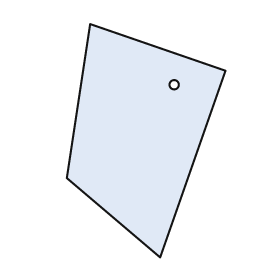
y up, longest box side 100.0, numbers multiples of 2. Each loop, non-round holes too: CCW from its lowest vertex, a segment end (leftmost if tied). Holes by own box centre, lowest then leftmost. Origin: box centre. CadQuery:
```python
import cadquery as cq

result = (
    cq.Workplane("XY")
    .moveTo(6.0, -50.0)
    .lineTo(34.0, 30.0)
    .lineTo(-24.0, 50.0)
    .lineTo(-34.0, -16.0)
    .close()
    .moveTo(12.0, 24.0)
    .circle(2.0)
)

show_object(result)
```